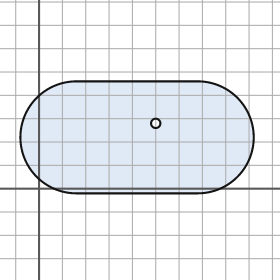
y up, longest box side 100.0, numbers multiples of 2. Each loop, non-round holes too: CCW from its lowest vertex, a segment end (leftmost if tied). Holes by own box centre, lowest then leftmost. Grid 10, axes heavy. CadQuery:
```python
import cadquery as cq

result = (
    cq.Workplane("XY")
    .moveTo(16.0, -2.0)
    .lineTo(68.0, -2.0)
    .threePointArc((92.0, 22.0), (68.0, 46.0))
    .lineTo(16.0, 46.0)
    .threePointArc((-8.0, 22.0), (16.0, -2.0))
    .close()
    .moveTo(50.0, 28.0)
    .circle(2.0)
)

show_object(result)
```